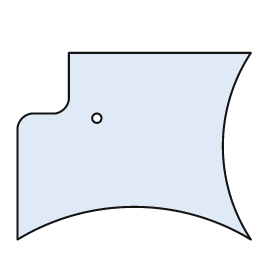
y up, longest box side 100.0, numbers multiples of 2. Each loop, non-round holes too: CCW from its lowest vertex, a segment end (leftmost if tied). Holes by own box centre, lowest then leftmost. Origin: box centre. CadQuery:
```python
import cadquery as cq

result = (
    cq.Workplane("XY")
    .moveTo(-50.0, -40.0)
    .threePointArc((0.0, -26.0), (50.0, -40.0))
    .threePointArc((38.0, 0.0), (50.0, 40.0))
    .lineTo(-28.0, 40.0)
    .lineTo(-28.0, 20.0)
    .threePointArc((-30.0, 16.0), (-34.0, 14.0))
    .lineTo(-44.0, 14.0)
    .threePointArc((-48.0, 12.0), (-50.0, 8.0))
    .close()
    .moveTo(-16.0, 12.0)
    .circle(2.0)
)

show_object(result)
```